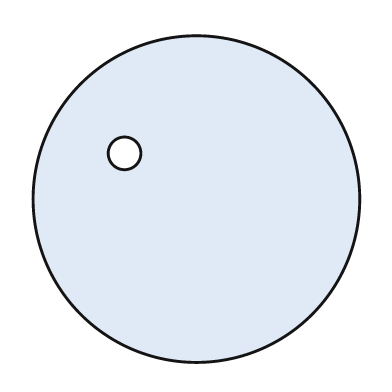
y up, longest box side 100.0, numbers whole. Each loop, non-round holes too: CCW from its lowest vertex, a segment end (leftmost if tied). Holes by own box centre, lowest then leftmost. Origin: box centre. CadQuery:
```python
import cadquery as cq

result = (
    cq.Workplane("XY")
    .moveTo(0.0, 0.0)
    .circle(50.0)
    .moveTo(-22.0, 14.0)
    .circle(5.0)
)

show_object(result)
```